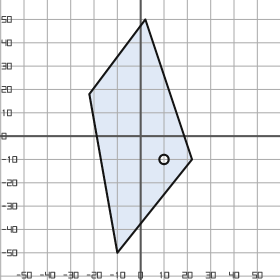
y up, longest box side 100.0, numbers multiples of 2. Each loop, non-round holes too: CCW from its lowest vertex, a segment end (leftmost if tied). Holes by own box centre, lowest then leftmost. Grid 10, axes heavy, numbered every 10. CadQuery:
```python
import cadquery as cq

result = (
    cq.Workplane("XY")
    .moveTo(-10.0, -50.0)
    .lineTo(22.0, -10.0)
    .lineTo(2.0, 50.0)
    .lineTo(-22.0, 18.0)
    .close()
    .moveTo(10.0, -10.0)
    .circle(2.0)
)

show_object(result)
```